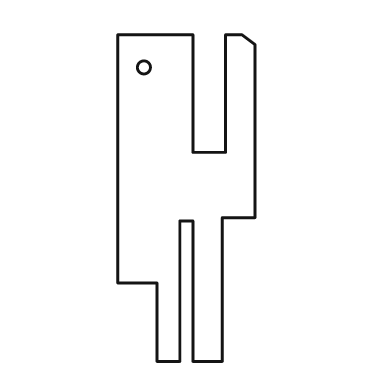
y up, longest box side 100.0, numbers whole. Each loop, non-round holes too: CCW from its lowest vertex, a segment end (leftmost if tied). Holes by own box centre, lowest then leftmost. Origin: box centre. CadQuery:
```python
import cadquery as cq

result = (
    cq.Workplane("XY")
    .moveTo(-9.0, -50.0)
    .lineTo(-2.0, -50.0)
    .lineTo(-2.0, -7.0)
    .lineTo(2.0, -7.0)
    .lineTo(2.0, -50.0)
    .lineTo(11.0, -50.0)
    .lineTo(11.0, -6.0)
    .lineTo(21.0, -6.0)
    .lineTo(21.0, 47.0)
    .lineTo(17.0, 50.0)
    .lineTo(12.0, 50.0)
    .lineTo(12.0, 14.0)
    .lineTo(2.0, 14.0)
    .lineTo(2.0, 50.0)
    .lineTo(-21.0, 50.0)
    .lineTo(-21.0, -26.0)
    .lineTo(-9.0, -26.0)
    .close()
    .moveTo(-13.0, 40.0)
    .circle(2.0)
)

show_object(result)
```